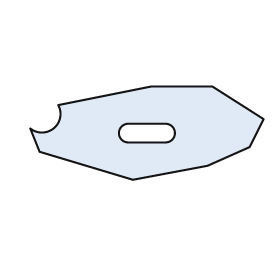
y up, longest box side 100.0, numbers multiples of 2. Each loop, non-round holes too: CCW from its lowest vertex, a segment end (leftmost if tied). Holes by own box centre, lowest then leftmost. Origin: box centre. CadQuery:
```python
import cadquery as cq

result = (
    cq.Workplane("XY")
    .moveTo(-6.0, -20.0)
    .lineTo(26.0, -14.0)
    .lineTo(44.0, -6.0)
    .lineTo(50.0, 6.0)
    .lineTo(28.0, 20.0)
    .lineTo(2.0, 20.0)
    .lineTo(-38.0, 12.0)
    .threePointArc((-40.0, 2.0), (-50.0, 2.0))
    .lineTo(-46.0, -8.0)
    .close()
    .moveTo(-8.0, -4.0)
    .lineTo(8.0, -4.0)
    .threePointArc((12.0, 0.0), (8.0, 4.0))
    .lineTo(-8.0, 4.0)
    .threePointArc((-12.0, 0.0), (-8.0, -4.0))
    .close()
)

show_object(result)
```